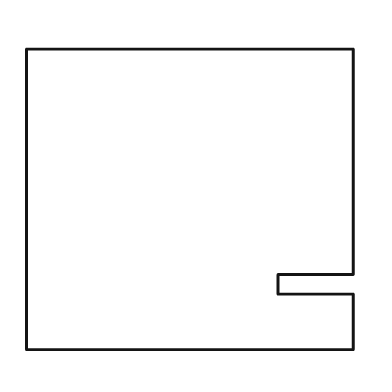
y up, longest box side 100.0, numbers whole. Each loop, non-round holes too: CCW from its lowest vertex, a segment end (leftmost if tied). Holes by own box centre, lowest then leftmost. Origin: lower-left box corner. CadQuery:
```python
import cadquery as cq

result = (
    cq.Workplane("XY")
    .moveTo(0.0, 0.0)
    .lineTo(100.0, 0.0)
    .lineTo(100.0, 17.0)
    .lineTo(77.0, 17.0)
    .lineTo(77.0, 23.0)
    .lineTo(100.0, 23.0)
    .lineTo(100.0, 92.0)
    .lineTo(0.0, 92.0)
    .close()
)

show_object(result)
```